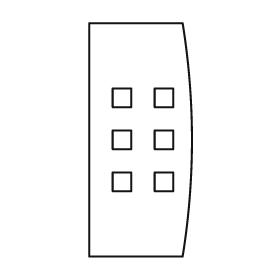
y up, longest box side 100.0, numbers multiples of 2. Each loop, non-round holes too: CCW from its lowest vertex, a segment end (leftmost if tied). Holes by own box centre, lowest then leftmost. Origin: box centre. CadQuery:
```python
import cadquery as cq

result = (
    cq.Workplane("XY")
    .moveTo(-22.0, -50.0)
    .lineTo(18.0, -50.0)
    .threePointArc((22.0, 0.0), (18.0, 50.0))
    .lineTo(-22.0, 50.0)
    .close()
    .moveTo(-12.0, -22.0)
    .lineTo(-4.0, -22.0)
    .lineTo(-4.0, -14.0)
    .lineTo(-12.0, -14.0)
    .close()
    .moveTo(6.0, -22.0)
    .lineTo(14.0, -22.0)
    .lineTo(14.0, -14.0)
    .lineTo(6.0, -14.0)
    .close()
    .moveTo(-12.0, -4.0)
    .lineTo(-4.0, -4.0)
    .lineTo(-4.0, 4.0)
    .lineTo(-12.0, 4.0)
    .close()
    .moveTo(6.0, -4.0)
    .lineTo(14.0, -4.0)
    .lineTo(14.0, 4.0)
    .lineTo(6.0, 4.0)
    .close()
    .moveTo(-12.0, 14.0)
    .lineTo(-4.0, 14.0)
    .lineTo(-4.0, 22.0)
    .lineTo(-12.0, 22.0)
    .close()
    .moveTo(6.0, 14.0)
    .lineTo(14.0, 14.0)
    .lineTo(14.0, 22.0)
    .lineTo(6.0, 22.0)
    .close()
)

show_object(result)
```